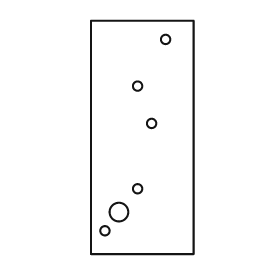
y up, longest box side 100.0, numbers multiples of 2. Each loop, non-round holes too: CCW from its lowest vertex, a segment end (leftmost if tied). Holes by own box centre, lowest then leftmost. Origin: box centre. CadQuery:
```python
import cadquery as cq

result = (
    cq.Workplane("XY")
    .moveTo(-22.0, -50.0)
    .lineTo(22.0, -50.0)
    .lineTo(22.0, 50.0)
    .lineTo(-22.0, 50.0)
    .close()
    .moveTo(-16.0, -40.0)
    .circle(2.0)
    .moveTo(-10.0, -32.0)
    .circle(4.0)
    .moveTo(-2.0, -22.0)
    .circle(2.0)
    .moveTo(4.0, 6.0)
    .circle(2.0)
    .moveTo(-2.0, 22.0)
    .circle(2.0)
    .moveTo(10.0, 42.0)
    .circle(2.0)
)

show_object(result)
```